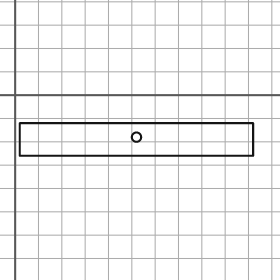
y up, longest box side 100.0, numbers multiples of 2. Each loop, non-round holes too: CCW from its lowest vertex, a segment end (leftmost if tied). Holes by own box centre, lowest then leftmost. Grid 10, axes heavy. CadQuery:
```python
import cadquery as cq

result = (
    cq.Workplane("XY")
    .moveTo(2.0, -26.0)
    .lineTo(102.0, -26.0)
    .lineTo(102.0, -12.0)
    .lineTo(2.0, -12.0)
    .close()
    .moveTo(52.0, -18.0)
    .circle(2.0)
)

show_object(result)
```